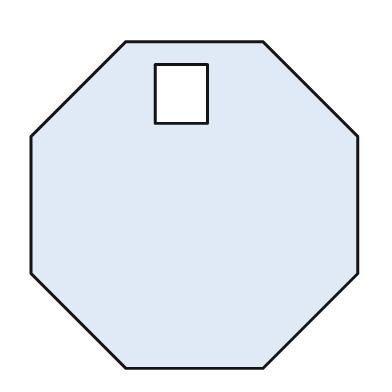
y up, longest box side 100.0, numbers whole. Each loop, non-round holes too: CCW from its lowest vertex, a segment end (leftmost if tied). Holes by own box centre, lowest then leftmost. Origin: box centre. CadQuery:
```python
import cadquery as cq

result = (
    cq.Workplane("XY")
    .moveTo(-21.0, -50.0)
    .lineTo(21.0, -50.0)
    .lineTo(50.0, -21.0)
    .lineTo(50.0, 21.0)
    .lineTo(21.0, 50.0)
    .lineTo(-21.0, 50.0)
    .lineTo(-50.0, 21.0)
    .lineTo(-50.0, -21.0)
    .close()
    .moveTo(-12.0, 25.0)
    .lineTo(4.0, 25.0)
    .lineTo(4.0, 43.0)
    .lineTo(-12.0, 43.0)
    .close()
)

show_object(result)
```